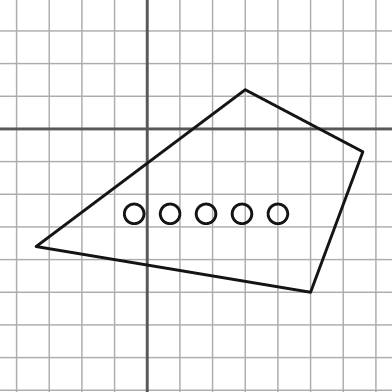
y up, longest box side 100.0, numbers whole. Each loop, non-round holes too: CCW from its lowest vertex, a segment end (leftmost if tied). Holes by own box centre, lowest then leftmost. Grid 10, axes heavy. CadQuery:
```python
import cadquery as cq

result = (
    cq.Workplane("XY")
    .moveTo(50.0, -50.0)
    .lineTo(66.0, -7.0)
    .lineTo(30.0, 12.0)
    .lineTo(-34.0, -36.0)
    .close()
    .moveTo(-4.0, -26.0)
    .circle(3.0)
    .moveTo(7.0, -26.0)
    .circle(3.0)
    .moveTo(18.0, -26.0)
    .circle(3.0)
    .moveTo(29.0, -26.0)
    .circle(3.0)
    .moveTo(40.0, -26.0)
    .circle(3.0)
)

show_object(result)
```